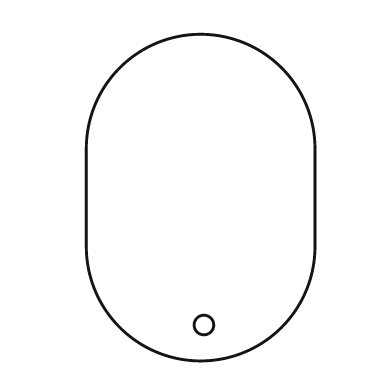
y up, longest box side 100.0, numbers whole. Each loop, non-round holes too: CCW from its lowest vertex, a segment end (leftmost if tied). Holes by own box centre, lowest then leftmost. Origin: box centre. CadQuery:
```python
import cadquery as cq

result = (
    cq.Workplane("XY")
    .moveTo(-35.0, -15.0)
    .threePointArc((0.0, -50.0), (35.0, -15.0))
    .lineTo(35.0, 15.0)
    .threePointArc((0.0, 50.0), (-35.0, 15.0))
    .close()
    .moveTo(1.0, -39.0)
    .circle(3.0)
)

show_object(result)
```